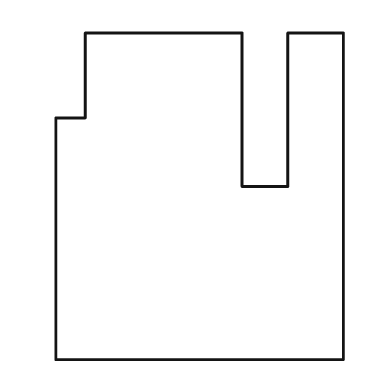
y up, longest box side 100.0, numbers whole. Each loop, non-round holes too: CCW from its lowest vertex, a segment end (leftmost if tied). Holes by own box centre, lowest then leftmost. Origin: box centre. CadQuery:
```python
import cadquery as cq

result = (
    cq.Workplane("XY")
    .moveTo(-44.0, -50.0)
    .lineTo(44.0, -50.0)
    .lineTo(44.0, 50.0)
    .lineTo(27.0, 50.0)
    .lineTo(27.0, 3.0)
    .lineTo(13.0, 3.0)
    .lineTo(13.0, 50.0)
    .lineTo(-35.0, 50.0)
    .lineTo(-35.0, 24.0)
    .lineTo(-44.0, 24.0)
    .close()
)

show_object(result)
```